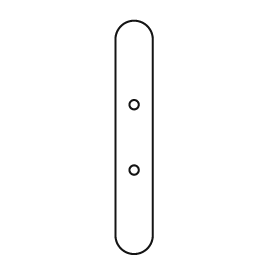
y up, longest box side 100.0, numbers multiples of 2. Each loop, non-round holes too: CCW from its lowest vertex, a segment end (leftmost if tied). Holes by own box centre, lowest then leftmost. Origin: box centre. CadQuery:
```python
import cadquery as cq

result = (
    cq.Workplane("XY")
    .moveTo(-8.0, -42.0)
    .threePointArc((0.0, -50.0), (8.0, -42.0))
    .lineTo(8.0, 42.0)
    .threePointArc((0.0, 50.0), (-8.0, 42.0))
    .close()
    .moveTo(0.0, -14.0)
    .circle(2.0)
    .moveTo(0.0, 14.0)
    .circle(2.0)
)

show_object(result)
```